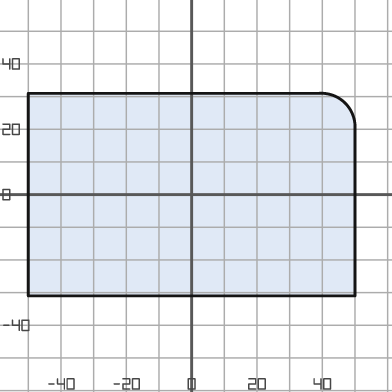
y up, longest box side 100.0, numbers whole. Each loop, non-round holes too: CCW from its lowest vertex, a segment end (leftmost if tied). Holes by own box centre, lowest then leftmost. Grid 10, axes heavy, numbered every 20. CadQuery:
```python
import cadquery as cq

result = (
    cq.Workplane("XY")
    .moveTo(-50.0, -31.0)
    .lineTo(50.0, -31.0)
    .lineTo(50.0, 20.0)
    .threePointArc((47.0, 28.0), (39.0, 31.0))
    .lineTo(-50.0, 31.0)
    .close()
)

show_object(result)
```